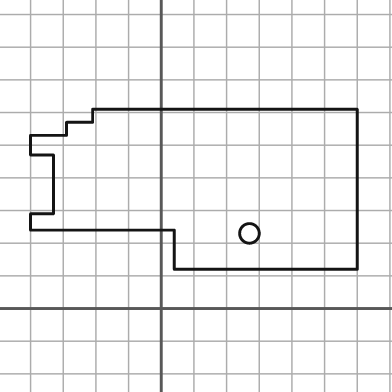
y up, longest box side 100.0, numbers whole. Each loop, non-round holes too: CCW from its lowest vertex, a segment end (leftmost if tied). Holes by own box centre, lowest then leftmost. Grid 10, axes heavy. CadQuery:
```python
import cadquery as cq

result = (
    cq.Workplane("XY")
    .moveTo(4.0, 12.0)
    .lineTo(60.0, 12.0)
    .lineTo(60.0, 61.0)
    .lineTo(-21.0, 61.0)
    .lineTo(-21.0, 57.0)
    .lineTo(-29.0, 57.0)
    .lineTo(-29.0, 53.0)
    .lineTo(-40.0, 53.0)
    .lineTo(-40.0, 47.0)
    .lineTo(-33.0, 47.0)
    .lineTo(-33.0, 29.0)
    .lineTo(-40.0, 29.0)
    .lineTo(-40.0, 24.0)
    .lineTo(4.0, 24.0)
    .close()
    .moveTo(27.0, 23.0)
    .circle(3.0)
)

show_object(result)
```